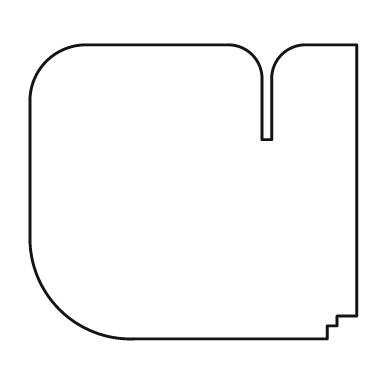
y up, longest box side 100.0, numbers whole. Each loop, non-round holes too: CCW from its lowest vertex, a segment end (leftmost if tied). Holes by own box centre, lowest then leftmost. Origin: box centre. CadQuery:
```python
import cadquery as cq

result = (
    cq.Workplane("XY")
    .moveTo(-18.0, -45.0)
    .lineTo(41.0, -45.0)
    .lineTo(41.0, -41.0)
    .lineTo(44.0, -41.0)
    .lineTo(44.0, -38.0)
    .lineTo(50.0, -38.0)
    .lineTo(50.0, 45.0)
    .lineTo(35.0, 45.0)
    .threePointArc((27.0, 42.0), (24.0, 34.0))
    .lineTo(24.0, 16.0)
    .lineTo(21.0, 16.0)
    .lineTo(21.0, 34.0)
    .threePointArc((18.0, 42.0), (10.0, 45.0))
    .lineTo(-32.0, 45.0)
    .threePointArc((-45.0, 40.0), (-50.0, 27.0))
    .lineTo(-50.0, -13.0)
    .threePointArc((-41.0, -36.0), (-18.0, -45.0))
    .close()
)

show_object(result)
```